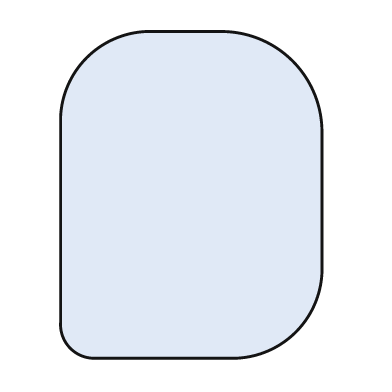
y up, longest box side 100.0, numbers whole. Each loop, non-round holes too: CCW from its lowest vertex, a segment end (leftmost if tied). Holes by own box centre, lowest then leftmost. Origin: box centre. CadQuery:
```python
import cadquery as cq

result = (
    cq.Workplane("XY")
    .moveTo(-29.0, -50.0)
    .lineTo(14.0, -50.0)
    .threePointArc((32.0, -42.0), (40.0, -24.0))
    .lineTo(40.0, 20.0)
    .threePointArc((31.0, 41.0), (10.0, 50.0))
    .lineTo(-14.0, 50.0)
    .threePointArc((-32.0, 42.0), (-40.0, 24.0))
    .lineTo(-40.0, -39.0)
    .threePointArc((-37.0, -47.0), (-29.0, -50.0))
    .close()
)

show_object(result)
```